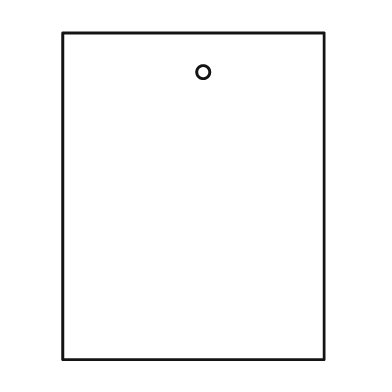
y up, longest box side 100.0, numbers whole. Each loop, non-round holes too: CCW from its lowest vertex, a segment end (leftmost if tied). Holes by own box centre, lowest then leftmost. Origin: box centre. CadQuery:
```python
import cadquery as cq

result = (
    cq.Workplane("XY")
    .moveTo(-40.0, -50.0)
    .lineTo(40.0, -50.0)
    .lineTo(40.0, 50.0)
    .lineTo(-40.0, 50.0)
    .close()
    .moveTo(3.0, 38.0)
    .circle(2.0)
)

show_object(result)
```